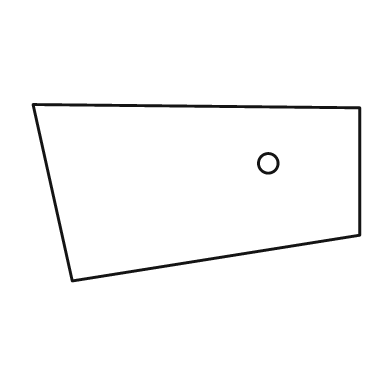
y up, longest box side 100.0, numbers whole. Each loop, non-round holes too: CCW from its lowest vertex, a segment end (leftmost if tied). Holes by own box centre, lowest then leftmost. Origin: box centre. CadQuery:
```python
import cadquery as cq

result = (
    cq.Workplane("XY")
    .moveTo(-38.0, -27.0)
    .lineTo(50.0, -13.0)
    .lineTo(50.0, 26.0)
    .lineTo(-50.0, 27.0)
    .close()
    .moveTo(22.0, 9.0)
    .circle(3.0)
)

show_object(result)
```